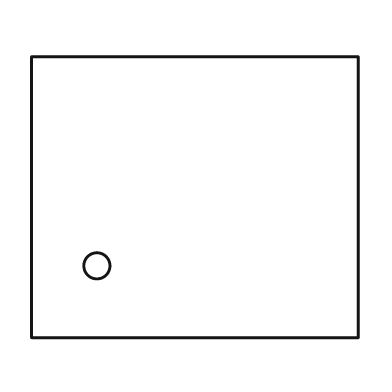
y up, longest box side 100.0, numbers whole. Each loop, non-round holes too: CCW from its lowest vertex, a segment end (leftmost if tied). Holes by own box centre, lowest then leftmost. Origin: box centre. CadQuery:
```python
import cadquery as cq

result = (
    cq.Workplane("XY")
    .moveTo(-50.0, -43.0)
    .lineTo(50.0, -43.0)
    .lineTo(50.0, 43.0)
    .lineTo(-50.0, 43.0)
    .close()
    .moveTo(-30.0, -21.0)
    .circle(4.0)
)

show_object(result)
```